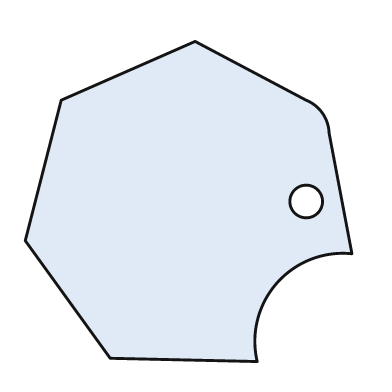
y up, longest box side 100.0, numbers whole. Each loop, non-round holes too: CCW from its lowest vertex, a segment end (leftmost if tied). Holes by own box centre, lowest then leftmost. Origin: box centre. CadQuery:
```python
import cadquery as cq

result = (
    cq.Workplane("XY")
    .moveTo(21.0, -49.0)
    .threePointArc((27.0, -25.0), (50.0, -16.0))
    .lineTo(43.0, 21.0)
    .threePointArc((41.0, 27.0), (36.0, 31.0))
    .lineTo(2.0, 49.0)
    .lineTo(-39.0, 31.0)
    .lineTo(-50.0, -12.0)
    .lineTo(-24.0, -48.0)
    .close()
    .moveTo(36.0, 0.0)
    .circle(5.0)
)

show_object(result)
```